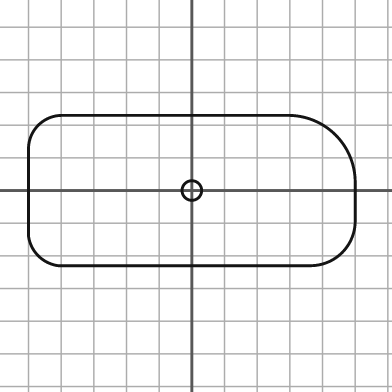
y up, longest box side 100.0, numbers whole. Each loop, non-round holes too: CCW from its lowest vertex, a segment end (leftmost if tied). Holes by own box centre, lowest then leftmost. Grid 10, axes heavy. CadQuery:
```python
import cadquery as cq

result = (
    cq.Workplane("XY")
    .moveTo(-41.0, -23.0)
    .lineTo(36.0, -23.0)
    .threePointArc((46.0, -19.0), (50.0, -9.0))
    .lineTo(50.0, 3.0)
    .threePointArc((44.0, 17.0), (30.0, 23.0))
    .lineTo(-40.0, 23.0)
    .threePointArc((-47.0, 20.0), (-50.0, 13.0))
    .lineTo(-50.0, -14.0)
    .threePointArc((-47.0, -20.0), (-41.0, -23.0))
    .close()
    .moveTo(0.0, 0.0)
    .circle(3.0)
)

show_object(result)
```